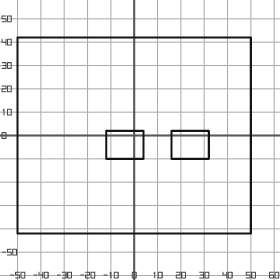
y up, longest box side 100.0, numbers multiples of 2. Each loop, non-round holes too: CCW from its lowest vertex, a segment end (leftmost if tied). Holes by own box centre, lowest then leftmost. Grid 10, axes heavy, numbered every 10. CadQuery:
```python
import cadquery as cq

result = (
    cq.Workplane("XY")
    .moveTo(-50.0, -42.0)
    .lineTo(50.0, -42.0)
    .lineTo(50.0, 42.0)
    .lineTo(-50.0, 42.0)
    .close()
    .moveTo(-12.0, -10.0)
    .lineTo(4.0, -10.0)
    .lineTo(4.0, 2.0)
    .lineTo(-12.0, 2.0)
    .close()
    .moveTo(16.0, -10.0)
    .lineTo(32.0, -10.0)
    .lineTo(32.0, 2.0)
    .lineTo(16.0, 2.0)
    .close()
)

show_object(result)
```